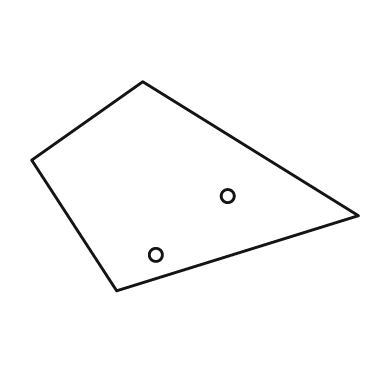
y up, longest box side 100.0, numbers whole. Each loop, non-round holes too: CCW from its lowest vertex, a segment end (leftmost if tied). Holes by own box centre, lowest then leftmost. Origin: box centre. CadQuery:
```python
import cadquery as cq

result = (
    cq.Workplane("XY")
    .moveTo(-24.0, -32.0)
    .lineTo(50.0, -9.0)
    .lineTo(-16.0, 32.0)
    .lineTo(-50.0, 8.0)
    .close()
    .moveTo(-12.0, -21.0)
    .circle(2.0)
    .moveTo(10.0, -3.0)
    .circle(2.0)
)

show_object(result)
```